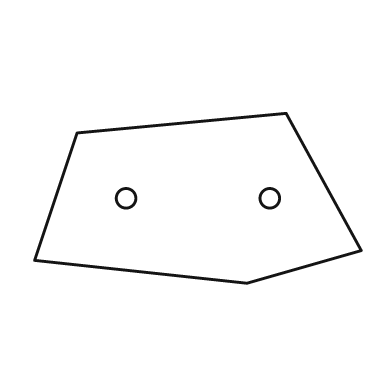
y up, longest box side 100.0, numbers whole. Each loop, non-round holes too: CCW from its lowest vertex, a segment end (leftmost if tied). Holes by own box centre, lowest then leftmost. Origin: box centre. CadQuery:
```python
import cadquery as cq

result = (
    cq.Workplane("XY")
    .moveTo(15.0, -26.0)
    .lineTo(50.0, -16.0)
    .lineTo(27.0, 26.0)
    .lineTo(-37.0, 20.0)
    .lineTo(-50.0, -19.0)
    .close()
    .moveTo(-22.0, 0.0)
    .circle(3.0)
    .moveTo(22.0, 0.0)
    .circle(3.0)
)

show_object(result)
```